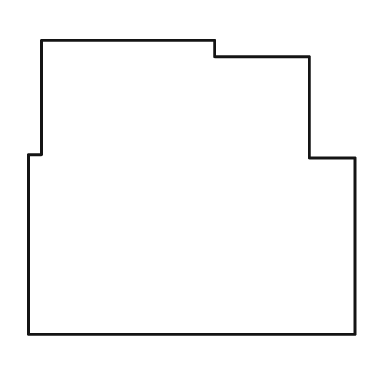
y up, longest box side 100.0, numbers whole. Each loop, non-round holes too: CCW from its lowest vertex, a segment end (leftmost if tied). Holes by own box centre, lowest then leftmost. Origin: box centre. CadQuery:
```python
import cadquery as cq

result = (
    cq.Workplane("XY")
    .moveTo(-50.0, -45.0)
    .lineTo(50.0, -45.0)
    .lineTo(50.0, 9.0)
    .lineTo(36.0, 9.0)
    .lineTo(36.0, 40.0)
    .lineTo(7.0, 40.0)
    .lineTo(7.0, 45.0)
    .lineTo(-46.0, 45.0)
    .lineTo(-46.0, 10.0)
    .lineTo(-50.0, 10.0)
    .close()
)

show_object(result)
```